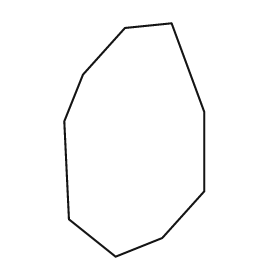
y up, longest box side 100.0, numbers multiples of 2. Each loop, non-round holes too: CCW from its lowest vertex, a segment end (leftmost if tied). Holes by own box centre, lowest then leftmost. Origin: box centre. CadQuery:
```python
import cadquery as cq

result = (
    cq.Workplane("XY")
    .moveTo(-8.0, -50.0)
    .lineTo(12.0, -42.0)
    .lineTo(30.0, -22.0)
    .lineTo(30.0, 12.0)
    .lineTo(16.0, 50.0)
    .lineTo(-4.0, 48.0)
    .lineTo(-22.0, 28.0)
    .lineTo(-30.0, 8.0)
    .lineTo(-28.0, -34.0)
    .close()
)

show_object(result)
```